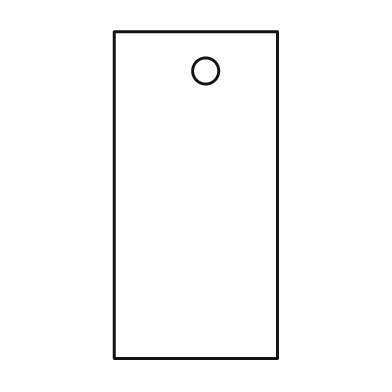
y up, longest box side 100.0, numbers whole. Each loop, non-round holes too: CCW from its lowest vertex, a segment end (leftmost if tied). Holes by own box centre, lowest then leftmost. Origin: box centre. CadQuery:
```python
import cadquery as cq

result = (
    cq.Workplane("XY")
    .moveTo(-25.0, -50.0)
    .lineTo(25.0, -50.0)
    .lineTo(25.0, 50.0)
    .lineTo(-25.0, 50.0)
    .close()
    .moveTo(3.0, 38.0)
    .circle(4.0)
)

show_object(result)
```